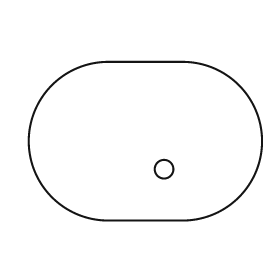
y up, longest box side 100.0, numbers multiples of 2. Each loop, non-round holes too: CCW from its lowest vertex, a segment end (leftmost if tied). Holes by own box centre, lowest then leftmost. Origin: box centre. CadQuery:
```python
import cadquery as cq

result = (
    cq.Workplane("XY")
    .moveTo(-16.0, -34.0)
    .lineTo(16.0, -34.0)
    .threePointArc((50.0, 0.0), (16.0, 34.0))
    .lineTo(-16.0, 34.0)
    .threePointArc((-50.0, 0.0), (-16.0, -34.0))
    .close()
    .moveTo(8.0, -12.0)
    .circle(4.0)
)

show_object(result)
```